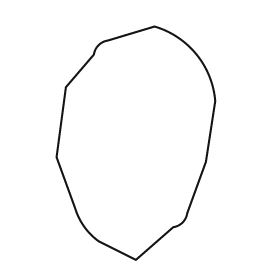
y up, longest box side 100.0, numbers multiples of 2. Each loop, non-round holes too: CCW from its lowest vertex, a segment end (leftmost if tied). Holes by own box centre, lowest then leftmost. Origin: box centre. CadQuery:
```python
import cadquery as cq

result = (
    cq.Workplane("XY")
    .moveTo(0.0, -50.0)
    .lineTo(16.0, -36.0)
    .threePointArc((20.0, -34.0), (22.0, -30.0))
    .lineTo(30.0, -8.0)
    .lineTo(34.0, 18.0)
    .threePointArc((26.0, 38.0), (8.0, 50.0))
    .lineTo(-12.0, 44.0)
    .threePointArc((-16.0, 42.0), (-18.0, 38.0))
    .lineTo(-30.0, 24.0)
    .lineTo(-34.0, -6.0)
    .lineTo(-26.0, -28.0)
    .threePointArc((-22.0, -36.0), (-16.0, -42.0))
    .close()
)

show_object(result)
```